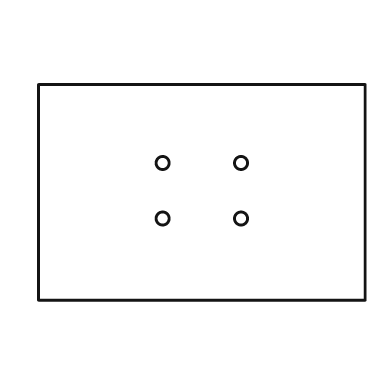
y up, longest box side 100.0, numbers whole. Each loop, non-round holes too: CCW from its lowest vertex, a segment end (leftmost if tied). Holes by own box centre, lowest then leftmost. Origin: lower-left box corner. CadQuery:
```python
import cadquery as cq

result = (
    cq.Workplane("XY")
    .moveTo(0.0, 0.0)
    .lineTo(100.0, 0.0)
    .lineTo(100.0, 66.0)
    .lineTo(0.0, 66.0)
    .close()
    .moveTo(38.0, 25.0)
    .circle(2.0)
    .moveTo(62.0, 25.0)
    .circle(2.0)
    .moveTo(38.0, 42.0)
    .circle(2.0)
    .moveTo(62.0, 42.0)
    .circle(2.0)
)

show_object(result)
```